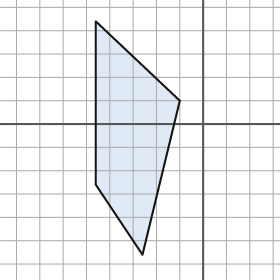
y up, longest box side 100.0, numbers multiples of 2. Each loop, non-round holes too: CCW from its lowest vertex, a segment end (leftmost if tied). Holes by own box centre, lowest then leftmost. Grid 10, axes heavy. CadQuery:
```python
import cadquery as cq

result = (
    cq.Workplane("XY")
    .moveTo(-26.0, -56.0)
    .lineTo(-10.0, 10.0)
    .lineTo(-46.0, 44.0)
    .lineTo(-46.0, -26.0)
    .close()
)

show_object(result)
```